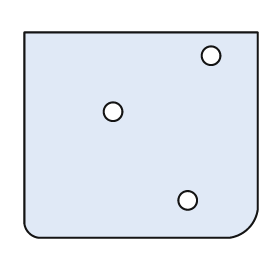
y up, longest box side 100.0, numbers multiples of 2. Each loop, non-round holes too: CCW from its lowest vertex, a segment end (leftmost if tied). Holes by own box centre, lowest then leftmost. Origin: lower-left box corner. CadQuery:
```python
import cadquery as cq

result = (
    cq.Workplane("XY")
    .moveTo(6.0, 0.0)
    .lineTo(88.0, 0.0)
    .threePointArc((96.0, 4.0), (100.0, 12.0))
    .lineTo(100.0, 88.0)
    .lineTo(0.0, 88.0)
    .lineTo(0.0, 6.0)
    .threePointArc((2.0, 2.0), (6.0, 0.0))
    .close()
    .moveTo(70.0, 16.0)
    .circle(4.0)
    .moveTo(38.0, 54.0)
    .circle(4.0)
    .moveTo(80.0, 78.0)
    .circle(4.0)
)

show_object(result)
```